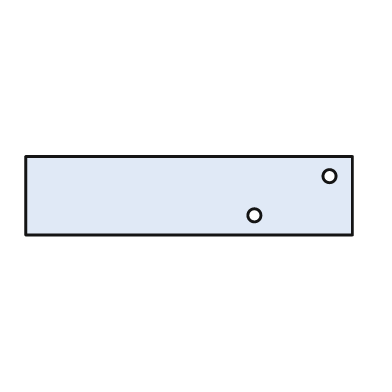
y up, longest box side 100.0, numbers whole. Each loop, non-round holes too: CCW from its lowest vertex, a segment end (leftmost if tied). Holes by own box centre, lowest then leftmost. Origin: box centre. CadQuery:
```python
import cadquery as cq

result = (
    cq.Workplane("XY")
    .moveTo(-50.0, -12.0)
    .lineTo(50.0, -12.0)
    .lineTo(50.0, 12.0)
    .lineTo(-50.0, 12.0)
    .close()
    .moveTo(20.0, -6.0)
    .circle(2.0)
    .moveTo(43.0, 6.0)
    .circle(2.0)
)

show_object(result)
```